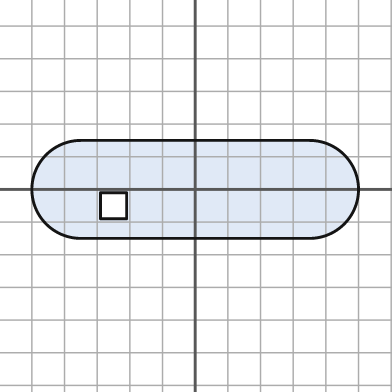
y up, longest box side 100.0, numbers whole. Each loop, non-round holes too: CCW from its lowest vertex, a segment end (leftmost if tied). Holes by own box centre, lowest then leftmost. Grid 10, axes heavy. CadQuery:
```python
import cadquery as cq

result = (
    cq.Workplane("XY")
    .moveTo(-35.0, -15.0)
    .lineTo(35.0, -15.0)
    .threePointArc((50.0, 0.0), (35.0, 15.0))
    .lineTo(-35.0, 15.0)
    .threePointArc((-50.0, 0.0), (-35.0, -15.0))
    .close()
    .moveTo(-29.0, -9.0)
    .lineTo(-21.0, -9.0)
    .lineTo(-21.0, -1.0)
    .lineTo(-29.0, -1.0)
    .close()
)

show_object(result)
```